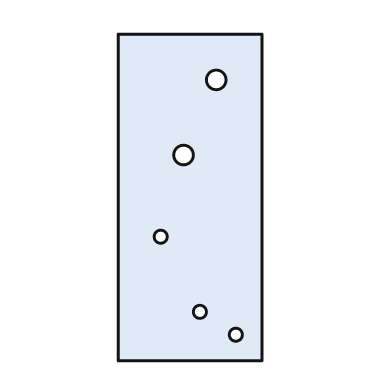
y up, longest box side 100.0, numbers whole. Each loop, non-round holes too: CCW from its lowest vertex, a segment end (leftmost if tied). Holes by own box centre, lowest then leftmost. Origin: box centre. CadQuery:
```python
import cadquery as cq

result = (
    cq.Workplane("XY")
    .moveTo(-22.0, -50.0)
    .lineTo(22.0, -50.0)
    .lineTo(22.0, 50.0)
    .lineTo(-22.0, 50.0)
    .close()
    .moveTo(14.0, -42.0)
    .circle(2.0)
    .moveTo(3.0, -35.0)
    .circle(2.0)
    .moveTo(-9.0, -12.0)
    .circle(2.0)
    .moveTo(-2.0, 13.0)
    .circle(3.0)
    .moveTo(8.0, 36.0)
    .circle(3.0)
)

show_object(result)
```